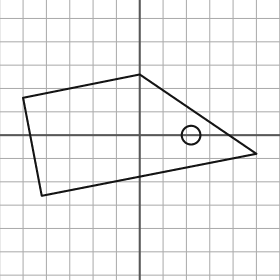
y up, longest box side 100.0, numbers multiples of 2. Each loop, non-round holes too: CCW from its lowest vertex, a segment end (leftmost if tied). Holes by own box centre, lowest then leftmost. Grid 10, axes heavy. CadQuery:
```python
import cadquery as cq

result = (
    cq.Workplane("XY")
    .moveTo(-42.0, -26.0)
    .lineTo(50.0, -8.0)
    .lineTo(0.0, 26.0)
    .lineTo(-50.0, 16.0)
    .close()
    .moveTo(22.0, 0.0)
    .circle(4.0)
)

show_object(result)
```